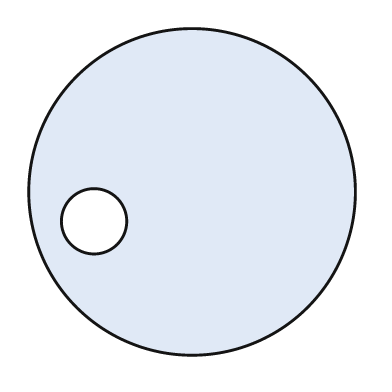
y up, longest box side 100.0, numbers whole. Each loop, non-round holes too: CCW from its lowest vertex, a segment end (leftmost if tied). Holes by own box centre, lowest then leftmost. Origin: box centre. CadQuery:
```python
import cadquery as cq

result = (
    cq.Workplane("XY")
    .moveTo(0.0, 0.0)
    .circle(50.0)
    .moveTo(-30.0, -9.0)
    .circle(10.0)
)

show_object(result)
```